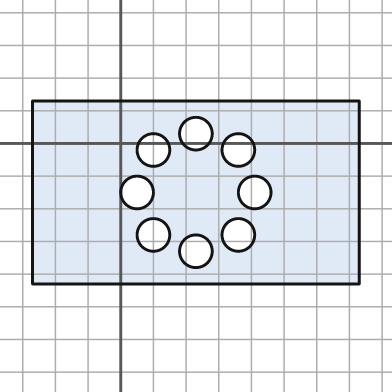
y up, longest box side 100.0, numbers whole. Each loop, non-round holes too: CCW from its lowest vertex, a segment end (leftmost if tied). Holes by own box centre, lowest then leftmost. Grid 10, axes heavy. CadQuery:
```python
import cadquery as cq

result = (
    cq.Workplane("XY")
    .moveTo(-27.0, -43.0)
    .lineTo(73.0, -43.0)
    .lineTo(73.0, 13.0)
    .lineTo(-27.0, 13.0)
    .close()
    .moveTo(23.0, -33.0)
    .circle(5.0)
    .moveTo(10.0, -28.0)
    .circle(5.0)
    .moveTo(36.0, -28.0)
    .circle(5.0)
    .moveTo(5.0, -15.0)
    .circle(5.0)
    .moveTo(41.0, -15.0)
    .circle(5.0)
    .moveTo(10.0, -2.0)
    .circle(5.0)
    .moveTo(36.0, -2.0)
    .circle(5.0)
    .moveTo(23.0, 3.0)
    .circle(5.0)
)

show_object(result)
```